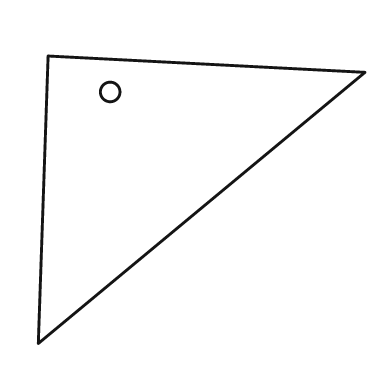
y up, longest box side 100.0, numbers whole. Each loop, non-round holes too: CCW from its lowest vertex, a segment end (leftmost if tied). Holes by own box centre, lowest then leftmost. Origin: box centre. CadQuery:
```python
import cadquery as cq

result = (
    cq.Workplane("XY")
    .moveTo(-50.0, -44.0)
    .lineTo(50.0, 39.0)
    .lineTo(-47.0, 44.0)
    .close()
    .moveTo(-28.0, 33.0)
    .circle(3.0)
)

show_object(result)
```